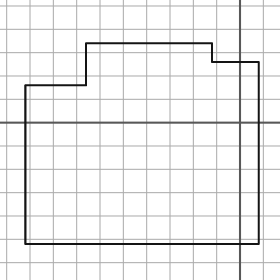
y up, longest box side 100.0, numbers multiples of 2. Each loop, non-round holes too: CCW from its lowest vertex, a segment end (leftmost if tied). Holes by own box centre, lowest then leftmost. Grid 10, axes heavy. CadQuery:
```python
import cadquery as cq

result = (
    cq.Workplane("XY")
    .moveTo(-92.0, -52.0)
    .lineTo(8.0, -52.0)
    .lineTo(8.0, 26.0)
    .lineTo(-12.0, 26.0)
    .lineTo(-12.0, 34.0)
    .lineTo(-66.0, 34.0)
    .lineTo(-66.0, 16.0)
    .lineTo(-92.0, 16.0)
    .close()
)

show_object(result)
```